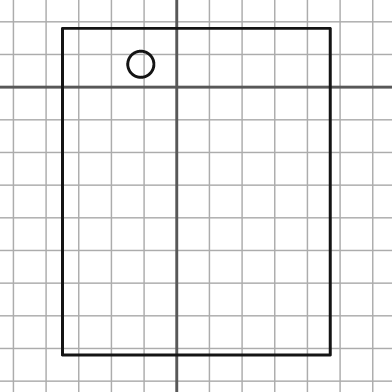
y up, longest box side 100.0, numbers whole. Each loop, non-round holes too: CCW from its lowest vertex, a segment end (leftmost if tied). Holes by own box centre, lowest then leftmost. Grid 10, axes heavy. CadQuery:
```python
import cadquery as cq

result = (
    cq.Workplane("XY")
    .moveTo(-35.0, -82.0)
    .lineTo(47.0, -82.0)
    .lineTo(47.0, 18.0)
    .lineTo(-35.0, 18.0)
    .close()
    .moveTo(-11.0, 7.0)
    .circle(4.0)
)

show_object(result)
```